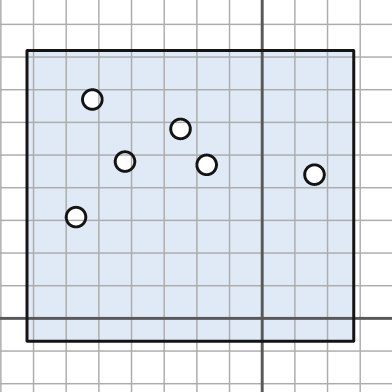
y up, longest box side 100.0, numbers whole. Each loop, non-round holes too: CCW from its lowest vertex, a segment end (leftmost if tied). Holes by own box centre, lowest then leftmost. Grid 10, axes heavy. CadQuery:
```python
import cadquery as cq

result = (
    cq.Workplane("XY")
    .moveTo(-72.0, -7.0)
    .lineTo(28.0, -7.0)
    .lineTo(28.0, 82.0)
    .lineTo(-72.0, 82.0)
    .close()
    .moveTo(-57.0, 31.0)
    .circle(3.0)
    .moveTo(16.0, 44.0)
    .circle(3.0)
    .moveTo(-17.0, 47.0)
    .circle(3.0)
    .moveTo(-42.0, 48.0)
    .circle(3.0)
    .moveTo(-25.0, 58.0)
    .circle(3.0)
    .moveTo(-52.0, 67.0)
    .circle(3.0)
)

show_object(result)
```